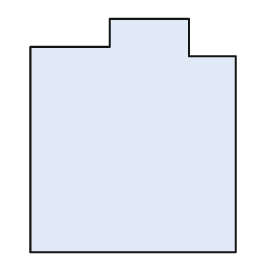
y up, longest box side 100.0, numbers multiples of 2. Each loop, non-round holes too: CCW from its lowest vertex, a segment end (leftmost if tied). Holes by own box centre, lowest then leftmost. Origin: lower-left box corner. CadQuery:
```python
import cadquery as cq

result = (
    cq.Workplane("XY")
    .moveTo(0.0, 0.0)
    .lineTo(88.0, 0.0)
    .lineTo(88.0, 84.0)
    .lineTo(68.0, 84.0)
    .lineTo(68.0, 100.0)
    .lineTo(34.0, 100.0)
    .lineTo(34.0, 88.0)
    .lineTo(0.0, 88.0)
    .close()
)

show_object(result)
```